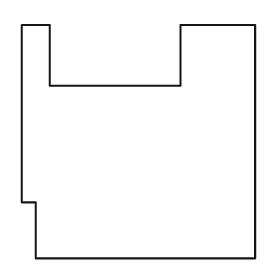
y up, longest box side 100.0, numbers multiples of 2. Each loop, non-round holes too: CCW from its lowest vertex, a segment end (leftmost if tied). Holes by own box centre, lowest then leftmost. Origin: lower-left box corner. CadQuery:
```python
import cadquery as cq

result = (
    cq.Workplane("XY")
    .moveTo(6.0, 0.0)
    .lineTo(100.0, 0.0)
    .lineTo(100.0, 100.0)
    .lineTo(68.0, 100.0)
    .lineTo(68.0, 74.0)
    .lineTo(12.0, 74.0)
    .lineTo(12.0, 100.0)
    .lineTo(0.0, 100.0)
    .lineTo(0.0, 24.0)
    .lineTo(6.0, 24.0)
    .close()
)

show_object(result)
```